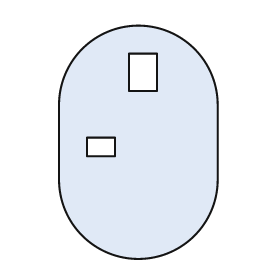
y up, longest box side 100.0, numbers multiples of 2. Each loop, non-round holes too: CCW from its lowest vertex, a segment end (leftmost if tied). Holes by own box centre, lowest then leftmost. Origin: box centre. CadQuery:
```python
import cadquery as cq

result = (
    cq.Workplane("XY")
    .moveTo(-34.0, -16.0)
    .threePointArc((0.0, -50.0), (34.0, -16.0))
    .lineTo(34.0, 16.0)
    .threePointArc((0.0, 50.0), (-34.0, 16.0))
    .close()
    .moveTo(-22.0, -6.0)
    .lineTo(-10.0, -6.0)
    .lineTo(-10.0, 2.0)
    .lineTo(-22.0, 2.0)
    .close()
    .moveTo(-4.0, 22.0)
    .lineTo(8.0, 22.0)
    .lineTo(8.0, 38.0)
    .lineTo(-4.0, 38.0)
    .close()
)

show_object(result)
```